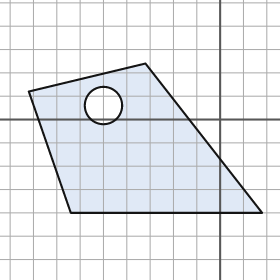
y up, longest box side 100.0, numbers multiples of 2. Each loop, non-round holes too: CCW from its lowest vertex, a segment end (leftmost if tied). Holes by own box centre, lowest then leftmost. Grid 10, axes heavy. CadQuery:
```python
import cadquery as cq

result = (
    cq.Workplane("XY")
    .moveTo(-64.0, -40.0)
    .lineTo(18.0, -40.0)
    .lineTo(-32.0, 24.0)
    .lineTo(-82.0, 12.0)
    .close()
    .moveTo(-50.0, 6.0)
    .circle(8.0)
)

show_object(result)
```